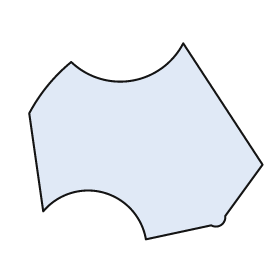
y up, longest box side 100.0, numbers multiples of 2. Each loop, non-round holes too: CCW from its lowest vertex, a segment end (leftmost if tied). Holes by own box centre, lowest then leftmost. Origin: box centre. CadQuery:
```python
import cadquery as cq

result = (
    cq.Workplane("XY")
    .moveTo(0.0, -42.0)
    .lineTo(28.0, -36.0)
    .threePointArc((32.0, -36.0), (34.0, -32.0))
    .lineTo(50.0, -10.0)
    .lineTo(16.0, 42.0)
    .threePointArc((-6.0, 26.0), (-32.0, 34.0))
    .threePointArc((-42.0, 24.0), (-50.0, 12.0))
    .lineTo(-44.0, -30.0)
    .threePointArc((-18.0, -22.0), (0.0, -42.0))
    .close()
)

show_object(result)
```